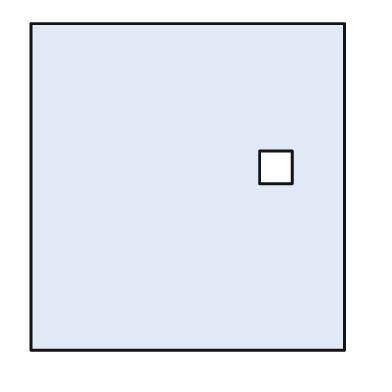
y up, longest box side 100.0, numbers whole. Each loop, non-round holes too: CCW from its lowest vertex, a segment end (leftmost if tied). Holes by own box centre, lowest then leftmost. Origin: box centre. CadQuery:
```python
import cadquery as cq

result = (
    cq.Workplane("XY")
    .moveTo(-48.0, -50.0)
    .lineTo(48.0, -50.0)
    .lineTo(48.0, 50.0)
    .lineTo(-48.0, 50.0)
    .close()
    .moveTo(22.0, 1.0)
    .lineTo(32.0, 1.0)
    .lineTo(32.0, 11.0)
    .lineTo(22.0, 11.0)
    .close()
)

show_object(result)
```